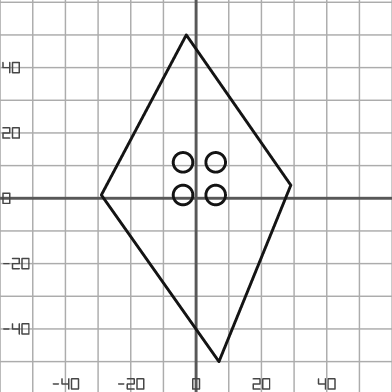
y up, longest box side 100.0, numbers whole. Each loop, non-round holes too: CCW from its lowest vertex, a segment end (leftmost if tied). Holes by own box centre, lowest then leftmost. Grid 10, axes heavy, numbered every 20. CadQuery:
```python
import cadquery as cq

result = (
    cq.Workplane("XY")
    .moveTo(7.0, -50.0)
    .lineTo(29.0, 4.0)
    .lineTo(-3.0, 50.0)
    .lineTo(-29.0, 1.0)
    .close()
    .moveTo(-4.0, 1.0)
    .circle(3.0)
    .moveTo(6.0, 1.0)
    .circle(3.0)
    .moveTo(-4.0, 11.0)
    .circle(3.0)
    .moveTo(6.0, 11.0)
    .circle(3.0)
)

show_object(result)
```